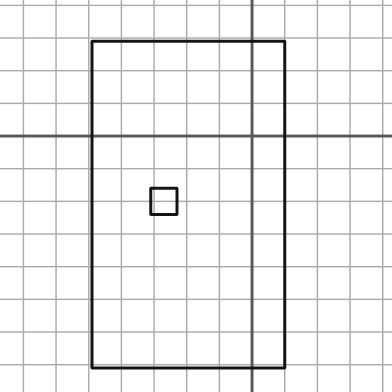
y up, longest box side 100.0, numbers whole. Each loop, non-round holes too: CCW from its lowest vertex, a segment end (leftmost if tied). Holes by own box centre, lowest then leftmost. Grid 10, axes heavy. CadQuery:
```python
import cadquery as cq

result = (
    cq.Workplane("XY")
    .moveTo(-49.0, -71.0)
    .lineTo(10.0, -71.0)
    .lineTo(10.0, 29.0)
    .lineTo(-49.0, 29.0)
    .close()
    .moveTo(-31.0, -24.0)
    .lineTo(-23.0, -24.0)
    .lineTo(-23.0, -16.0)
    .lineTo(-31.0, -16.0)
    .close()
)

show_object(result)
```